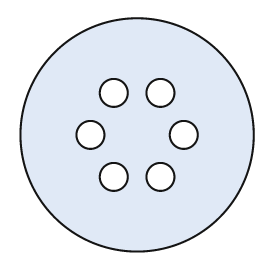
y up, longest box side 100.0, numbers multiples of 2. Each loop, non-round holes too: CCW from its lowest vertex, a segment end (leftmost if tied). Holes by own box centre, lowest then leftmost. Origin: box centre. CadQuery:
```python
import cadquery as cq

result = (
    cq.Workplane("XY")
    .moveTo(0.0, 0.0)
    .circle(50.0)
    .moveTo(-10.0, -18.0)
    .circle(6.0)
    .moveTo(10.0, -18.0)
    .circle(6.0)
    .moveTo(-20.0, 0.0)
    .circle(6.0)
    .moveTo(20.0, 0.0)
    .circle(6.0)
    .moveTo(-10.0, 18.0)
    .circle(6.0)
    .moveTo(10.0, 18.0)
    .circle(6.0)
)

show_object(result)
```